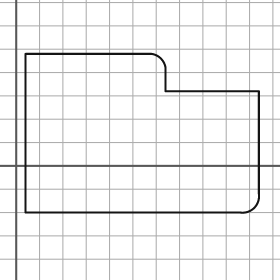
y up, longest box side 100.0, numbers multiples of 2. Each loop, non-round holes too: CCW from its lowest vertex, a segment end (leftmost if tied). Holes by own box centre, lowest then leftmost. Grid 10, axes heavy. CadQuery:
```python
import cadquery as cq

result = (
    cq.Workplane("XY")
    .moveTo(4.0, -20.0)
    .lineTo(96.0, -20.0)
    .threePointArc((102.0, -18.0), (104.0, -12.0))
    .lineTo(104.0, 32.0)
    .lineTo(64.0, 32.0)
    .lineTo(64.0, 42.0)
    .threePointArc((62.0, 46.0), (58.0, 48.0))
    .lineTo(4.0, 48.0)
    .close()
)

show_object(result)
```